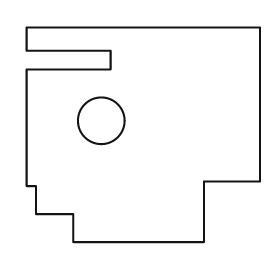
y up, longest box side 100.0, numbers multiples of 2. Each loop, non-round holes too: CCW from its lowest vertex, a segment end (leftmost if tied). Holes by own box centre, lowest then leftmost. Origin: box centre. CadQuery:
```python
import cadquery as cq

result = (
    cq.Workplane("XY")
    .moveTo(-30.0, -46.0)
    .lineTo(26.0, -46.0)
    .lineTo(26.0, -20.0)
    .lineTo(50.0, -20.0)
    .lineTo(50.0, 46.0)
    .lineTo(-50.0, 46.0)
    .lineTo(-50.0, 36.0)
    .lineTo(-14.0, 36.0)
    .lineTo(-14.0, 28.0)
    .lineTo(-50.0, 28.0)
    .lineTo(-50.0, -22.0)
    .lineTo(-46.0, -22.0)
    .lineTo(-46.0, -34.0)
    .lineTo(-30.0, -34.0)
    .close()
    .moveTo(-18.0, 6.0)
    .circle(10.0)
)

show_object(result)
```